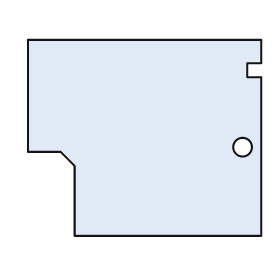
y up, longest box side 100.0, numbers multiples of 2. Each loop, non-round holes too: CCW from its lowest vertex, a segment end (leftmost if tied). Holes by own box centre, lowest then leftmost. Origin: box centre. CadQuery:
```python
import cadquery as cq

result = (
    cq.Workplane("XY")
    .moveTo(-30.0, -42.0)
    .lineTo(50.0, -42.0)
    .lineTo(50.0, 26.0)
    .lineTo(44.0, 26.0)
    .lineTo(44.0, 32.0)
    .lineTo(50.0, 32.0)
    .lineTo(50.0, 42.0)
    .lineTo(-50.0, 42.0)
    .lineTo(-50.0, -6.0)
    .lineTo(-36.0, -6.0)
    .lineTo(-30.0, -12.0)
    .close()
    .moveTo(42.0, -4.0)
    .circle(4.0)
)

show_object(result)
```